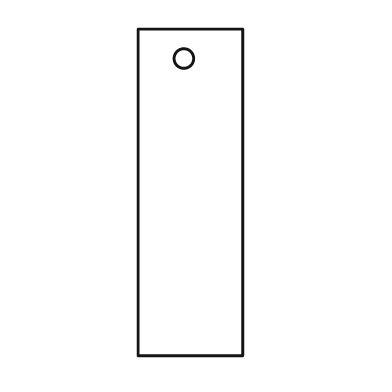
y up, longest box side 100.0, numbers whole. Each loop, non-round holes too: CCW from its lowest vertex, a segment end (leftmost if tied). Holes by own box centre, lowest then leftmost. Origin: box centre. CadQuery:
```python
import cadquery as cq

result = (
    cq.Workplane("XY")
    .moveTo(-16.0, -50.0)
    .lineTo(16.0, -50.0)
    .lineTo(16.0, 50.0)
    .lineTo(-16.0, 50.0)
    .close()
    .moveTo(-2.0, 41.0)
    .circle(3.0)
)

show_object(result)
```